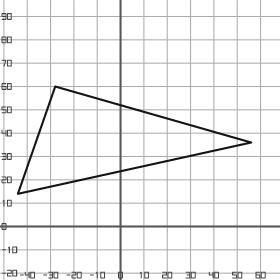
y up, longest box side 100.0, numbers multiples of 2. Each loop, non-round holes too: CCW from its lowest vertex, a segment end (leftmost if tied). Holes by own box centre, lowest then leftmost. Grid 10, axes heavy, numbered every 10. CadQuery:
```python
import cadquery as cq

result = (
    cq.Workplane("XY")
    .moveTo(-44.0, 14.0)
    .lineTo(56.0, 36.0)
    .lineTo(-28.0, 60.0)
    .close()
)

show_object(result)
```